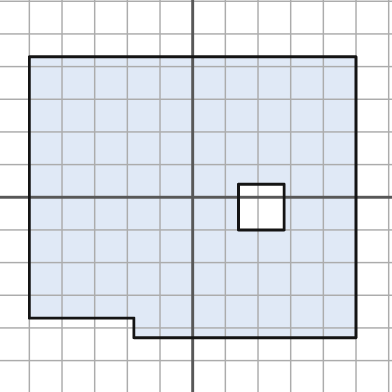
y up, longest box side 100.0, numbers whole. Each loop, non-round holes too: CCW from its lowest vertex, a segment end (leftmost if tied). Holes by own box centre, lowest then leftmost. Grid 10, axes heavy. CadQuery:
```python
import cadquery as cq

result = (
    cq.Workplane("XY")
    .moveTo(-18.0, -43.0)
    .lineTo(50.0, -43.0)
    .lineTo(50.0, 43.0)
    .lineTo(-50.0, 43.0)
    .lineTo(-50.0, -37.0)
    .lineTo(-18.0, -37.0)
    .close()
    .moveTo(14.0, -10.0)
    .lineTo(28.0, -10.0)
    .lineTo(28.0, 4.0)
    .lineTo(14.0, 4.0)
    .close()
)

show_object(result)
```